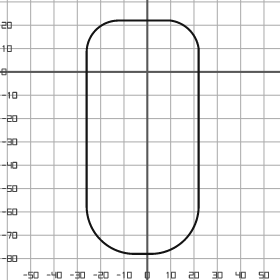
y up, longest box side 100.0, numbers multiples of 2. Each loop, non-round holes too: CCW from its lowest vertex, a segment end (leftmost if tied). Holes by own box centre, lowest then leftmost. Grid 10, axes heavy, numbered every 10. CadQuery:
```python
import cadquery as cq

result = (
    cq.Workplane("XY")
    .moveTo(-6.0, -78.0)
    .lineTo(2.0, -78.0)
    .threePointArc((16.0, -72.0), (22.0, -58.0))
    .lineTo(22.0, 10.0)
    .threePointArc((18.0, 18.0), (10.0, 22.0))
    .lineTo(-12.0, 22.0)
    .threePointArc((-22.0, 18.0), (-26.0, 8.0))
    .lineTo(-26.0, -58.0)
    .threePointArc((-20.0, -72.0), (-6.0, -78.0))
    .close()
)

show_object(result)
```